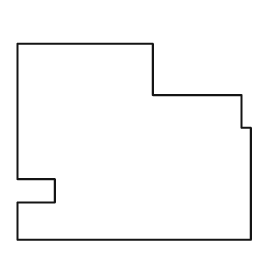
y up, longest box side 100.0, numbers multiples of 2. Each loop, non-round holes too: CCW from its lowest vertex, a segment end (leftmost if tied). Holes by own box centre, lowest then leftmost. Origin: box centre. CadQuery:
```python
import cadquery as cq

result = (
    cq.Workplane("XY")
    .moveTo(-50.0, -42.0)
    .lineTo(50.0, -42.0)
    .lineTo(50.0, 6.0)
    .lineTo(46.0, 6.0)
    .lineTo(46.0, 20.0)
    .lineTo(8.0, 20.0)
    .lineTo(8.0, 42.0)
    .lineTo(-50.0, 42.0)
    .lineTo(-50.0, -16.0)
    .lineTo(-34.0, -16.0)
    .lineTo(-34.0, -26.0)
    .lineTo(-50.0, -26.0)
    .close()
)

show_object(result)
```